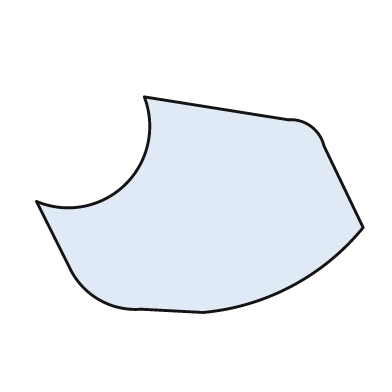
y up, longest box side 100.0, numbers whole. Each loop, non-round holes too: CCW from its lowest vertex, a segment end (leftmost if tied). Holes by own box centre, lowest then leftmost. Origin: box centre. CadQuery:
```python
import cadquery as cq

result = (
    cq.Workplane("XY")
    .moveTo(1.0, -33.0)
    .threePointArc((28.0, -25.0), (50.0, -7.0))
    .lineTo(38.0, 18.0)
    .threePointArc((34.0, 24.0), (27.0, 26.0))
    .lineTo(-17.0, 33.0)
    .threePointArc((-23.0, 6.0), (-50.0, 1.0))
    .lineTo(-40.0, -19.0)
    .threePointArc((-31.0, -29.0), (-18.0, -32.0))
    .close()
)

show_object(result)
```